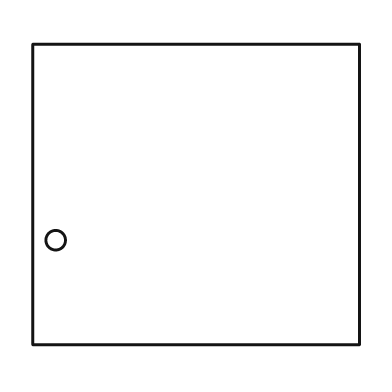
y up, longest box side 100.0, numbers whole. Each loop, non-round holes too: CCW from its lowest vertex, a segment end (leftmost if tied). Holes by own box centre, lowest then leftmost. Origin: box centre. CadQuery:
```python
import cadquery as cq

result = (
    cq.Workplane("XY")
    .moveTo(-50.0, -46.0)
    .lineTo(50.0, -46.0)
    .lineTo(50.0, 46.0)
    .lineTo(-50.0, 46.0)
    .close()
    .moveTo(-43.0, -14.0)
    .circle(3.0)
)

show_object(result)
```